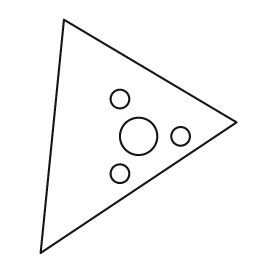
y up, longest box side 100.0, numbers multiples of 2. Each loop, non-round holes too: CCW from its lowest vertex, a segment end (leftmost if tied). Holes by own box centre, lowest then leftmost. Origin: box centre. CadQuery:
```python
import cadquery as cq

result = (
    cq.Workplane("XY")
    .moveTo(-42.0, -50.0)
    .lineTo(42.0, 6.0)
    .lineTo(-32.0, 50.0)
    .close()
    .moveTo(-8.0, -16.0)
    .circle(4.0)
    .moveTo(0.0, 0.0)
    .circle(8.0)
    .moveTo(18.0, 0.0)
    .circle(4.0)
    .moveTo(-8.0, 16.0)
    .circle(4.0)
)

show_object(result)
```